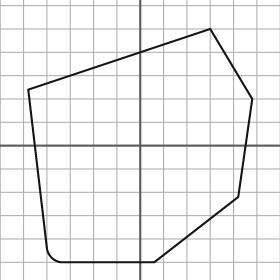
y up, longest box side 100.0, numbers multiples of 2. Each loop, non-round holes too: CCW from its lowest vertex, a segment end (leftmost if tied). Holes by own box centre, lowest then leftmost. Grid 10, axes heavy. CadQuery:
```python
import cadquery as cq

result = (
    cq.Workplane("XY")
    .moveTo(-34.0, -50.0)
    .lineTo(6.0, -50.0)
    .lineTo(42.0, -22.0)
    .lineTo(48.0, 20.0)
    .lineTo(30.0, 50.0)
    .lineTo(-48.0, 24.0)
    .lineTo(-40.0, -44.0)
    .threePointArc((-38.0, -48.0), (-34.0, -50.0))
    .close()
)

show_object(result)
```